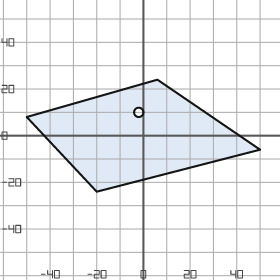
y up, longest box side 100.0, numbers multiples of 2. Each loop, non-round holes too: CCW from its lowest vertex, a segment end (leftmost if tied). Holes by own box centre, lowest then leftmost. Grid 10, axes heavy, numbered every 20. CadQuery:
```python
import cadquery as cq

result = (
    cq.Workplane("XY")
    .moveTo(-20.0, -24.0)
    .lineTo(50.0, -6.0)
    .lineTo(6.0, 24.0)
    .lineTo(-50.0, 8.0)
    .close()
    .moveTo(-2.0, 10.0)
    .circle(2.0)
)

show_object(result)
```